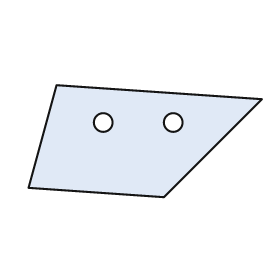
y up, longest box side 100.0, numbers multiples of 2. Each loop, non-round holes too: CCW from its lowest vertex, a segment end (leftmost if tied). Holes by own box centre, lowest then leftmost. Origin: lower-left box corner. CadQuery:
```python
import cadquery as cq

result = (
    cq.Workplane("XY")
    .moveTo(58.0, 0.0)
    .lineTo(100.0, 42.0)
    .lineTo(12.0, 48.0)
    .lineTo(0.0, 4.0)
    .close()
    .moveTo(32.0, 32.0)
    .circle(4.0)
    .moveTo(62.0, 32.0)
    .circle(4.0)
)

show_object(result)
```